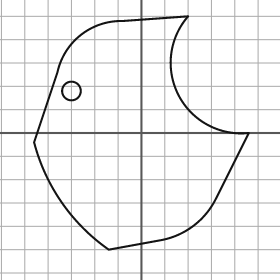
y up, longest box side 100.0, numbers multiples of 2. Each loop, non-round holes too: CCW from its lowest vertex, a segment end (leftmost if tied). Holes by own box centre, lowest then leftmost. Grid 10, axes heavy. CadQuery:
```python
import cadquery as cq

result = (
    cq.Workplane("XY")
    .moveTo(-14.0, -50.0)
    .lineTo(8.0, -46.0)
    .threePointArc((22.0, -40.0), (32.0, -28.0))
    .lineTo(46.0, 0.0)
    .threePointArc((16.0, 16.0), (20.0, 50.0))
    .lineTo(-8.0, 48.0)
    .threePointArc((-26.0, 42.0), (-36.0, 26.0))
    .lineTo(-46.0, -4.0)
    .threePointArc((-34.0, -30.0), (-14.0, -50.0))
    .close()
    .moveTo(-30.0, 18.0)
    .circle(4.0)
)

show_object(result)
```